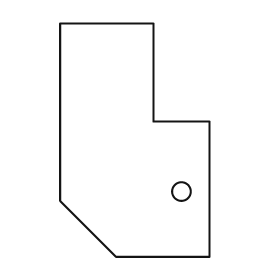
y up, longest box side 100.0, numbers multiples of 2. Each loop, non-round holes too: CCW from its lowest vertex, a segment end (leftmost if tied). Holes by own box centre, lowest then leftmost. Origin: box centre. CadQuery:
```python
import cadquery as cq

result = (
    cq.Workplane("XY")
    .moveTo(-8.0, -50.0)
    .lineTo(32.0, -50.0)
    .lineTo(32.0, 8.0)
    .lineTo(8.0, 8.0)
    .lineTo(8.0, 50.0)
    .lineTo(-32.0, 50.0)
    .lineTo(-32.0, -26.0)
    .close()
    .moveTo(20.0, -22.0)
    .circle(4.0)
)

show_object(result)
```